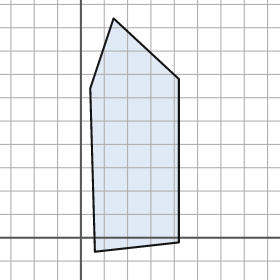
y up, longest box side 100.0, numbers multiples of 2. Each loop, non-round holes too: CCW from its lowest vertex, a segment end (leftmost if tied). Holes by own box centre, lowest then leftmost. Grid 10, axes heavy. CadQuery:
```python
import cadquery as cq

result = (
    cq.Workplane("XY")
    .moveTo(6.0, -6.0)
    .lineTo(42.0, -2.0)
    .lineTo(42.0, 68.0)
    .lineTo(14.0, 94.0)
    .lineTo(4.0, 64.0)
    .close()
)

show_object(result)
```